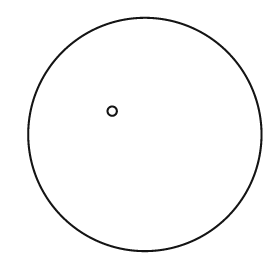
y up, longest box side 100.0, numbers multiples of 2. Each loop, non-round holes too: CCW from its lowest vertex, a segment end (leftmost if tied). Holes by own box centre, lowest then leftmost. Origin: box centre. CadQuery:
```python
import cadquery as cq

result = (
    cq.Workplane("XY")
    .moveTo(0.0, 0.0)
    .circle(50.0)
    .moveTo(-14.0, 10.0)
    .circle(2.0)
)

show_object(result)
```